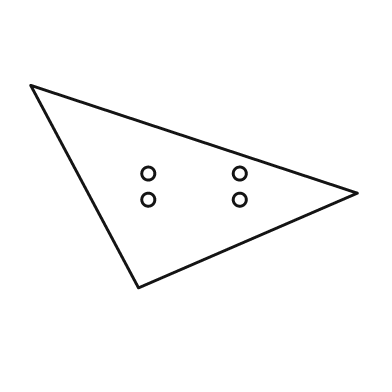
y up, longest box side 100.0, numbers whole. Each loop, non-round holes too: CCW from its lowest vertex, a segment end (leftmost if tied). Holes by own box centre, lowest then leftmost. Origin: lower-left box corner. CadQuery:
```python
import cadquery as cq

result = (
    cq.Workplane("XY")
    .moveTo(33.0, 0.0)
    .lineTo(100.0, 29.0)
    .lineTo(0.0, 62.0)
    .close()
    .moveTo(36.0, 27.0)
    .circle(2.0)
    .moveTo(64.0, 27.0)
    .circle(2.0)
    .moveTo(36.0, 35.0)
    .circle(2.0)
    .moveTo(64.0, 35.0)
    .circle(2.0)
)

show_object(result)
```